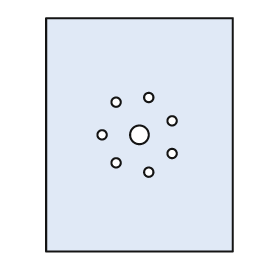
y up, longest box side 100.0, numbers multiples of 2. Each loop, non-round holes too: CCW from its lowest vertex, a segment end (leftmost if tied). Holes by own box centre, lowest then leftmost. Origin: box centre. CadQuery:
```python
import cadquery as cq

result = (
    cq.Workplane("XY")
    .moveTo(-40.0, -50.0)
    .lineTo(40.0, -50.0)
    .lineTo(40.0, 50.0)
    .lineTo(-40.0, 50.0)
    .close()
    .moveTo(4.0, -16.0)
    .circle(2.0)
    .moveTo(-10.0, -12.0)
    .circle(2.0)
    .moveTo(14.0, -8.0)
    .circle(2.0)
    .moveTo(-16.0, 0.0)
    .circle(2.0)
    .moveTo(0.0, 0.0)
    .circle(4.0)
    .moveTo(14.0, 6.0)
    .circle(2.0)
    .moveTo(-10.0, 14.0)
    .circle(2.0)
    .moveTo(4.0, 16.0)
    .circle(2.0)
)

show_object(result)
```